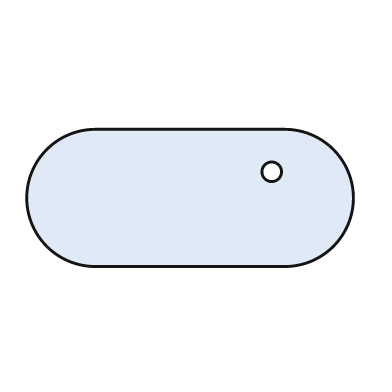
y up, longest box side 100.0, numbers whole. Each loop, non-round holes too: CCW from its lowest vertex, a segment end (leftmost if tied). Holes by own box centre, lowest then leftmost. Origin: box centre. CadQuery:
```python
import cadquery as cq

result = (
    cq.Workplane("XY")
    .moveTo(-29.0, -21.0)
    .lineTo(29.0, -21.0)
    .threePointArc((50.0, 0.0), (29.0, 21.0))
    .lineTo(-29.0, 21.0)
    .threePointArc((-50.0, 0.0), (-29.0, -21.0))
    .close()
    .moveTo(25.0, 8.0)
    .circle(3.0)
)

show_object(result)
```